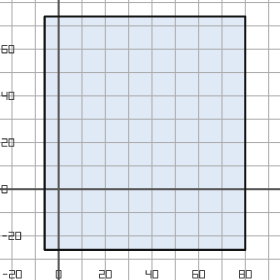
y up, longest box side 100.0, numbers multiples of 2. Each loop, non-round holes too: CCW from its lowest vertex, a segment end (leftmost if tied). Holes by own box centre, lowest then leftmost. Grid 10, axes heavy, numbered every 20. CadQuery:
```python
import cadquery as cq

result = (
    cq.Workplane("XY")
    .moveTo(-6.0, -26.0)
    .lineTo(80.0, -26.0)
    .lineTo(80.0, 74.0)
    .lineTo(-6.0, 74.0)
    .close()
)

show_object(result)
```